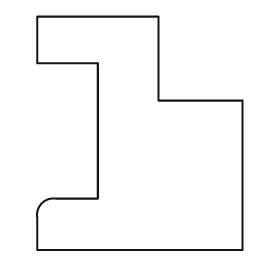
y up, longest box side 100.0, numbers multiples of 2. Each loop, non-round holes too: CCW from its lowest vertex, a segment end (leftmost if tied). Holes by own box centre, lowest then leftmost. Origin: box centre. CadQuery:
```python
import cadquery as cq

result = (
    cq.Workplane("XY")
    .moveTo(-44.0, -50.0)
    .lineTo(44.0, -50.0)
    .lineTo(44.0, 14.0)
    .lineTo(8.0, 14.0)
    .lineTo(8.0, 50.0)
    .lineTo(-44.0, 50.0)
    .lineTo(-44.0, 30.0)
    .lineTo(-18.0, 30.0)
    .lineTo(-18.0, -28.0)
    .lineTo(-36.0, -28.0)
    .threePointArc((-42.0, -30.0), (-44.0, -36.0))
    .close()
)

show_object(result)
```